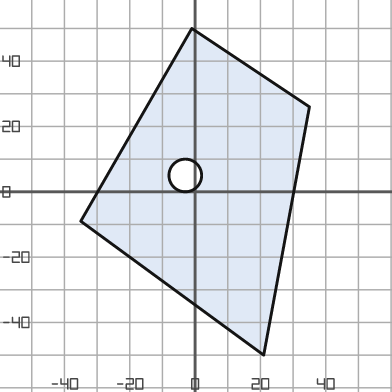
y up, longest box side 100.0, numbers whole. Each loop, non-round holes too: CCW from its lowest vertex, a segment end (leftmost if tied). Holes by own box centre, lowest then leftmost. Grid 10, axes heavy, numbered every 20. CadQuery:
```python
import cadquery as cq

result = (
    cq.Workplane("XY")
    .moveTo(21.0, -50.0)
    .lineTo(35.0, 26.0)
    .lineTo(-1.0, 50.0)
    .lineTo(-35.0, -9.0)
    .close()
    .moveTo(-3.0, 5.0)
    .circle(5.0)
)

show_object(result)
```